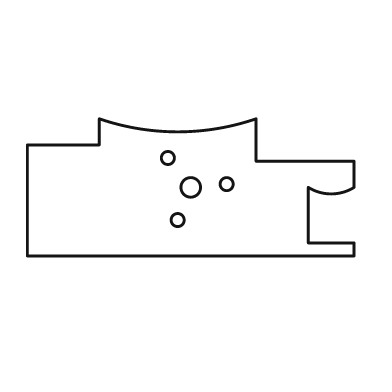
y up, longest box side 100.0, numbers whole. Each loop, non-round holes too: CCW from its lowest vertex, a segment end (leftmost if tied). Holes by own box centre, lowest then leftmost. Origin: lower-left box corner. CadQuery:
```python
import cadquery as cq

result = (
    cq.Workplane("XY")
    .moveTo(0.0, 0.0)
    .lineTo(100.0, 0.0)
    .lineTo(100.0, 4.0)
    .lineTo(86.0, 4.0)
    .lineTo(86.0, 21.0)
    .threePointArc((93.0, 19.0), (100.0, 21.0))
    .lineTo(100.0, 29.0)
    .lineTo(70.0, 29.0)
    .lineTo(70.0, 42.0)
    .threePointArc((46.0, 38.0), (22.0, 42.0))
    .lineTo(22.0, 34.0)
    .lineTo(0.0, 34.0)
    .close()
    .moveTo(46.0, 11.0)
    .circle(2.0)
    .moveTo(50.0, 21.0)
    .circle(3.0)
    .moveTo(61.0, 22.0)
    .circle(2.0)
    .moveTo(43.0, 30.0)
    .circle(2.0)
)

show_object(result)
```